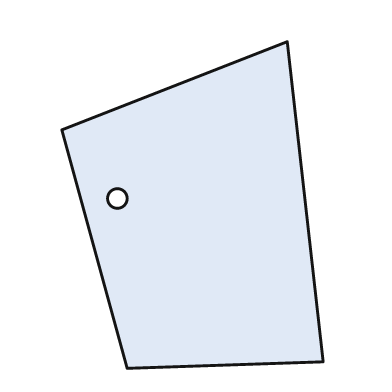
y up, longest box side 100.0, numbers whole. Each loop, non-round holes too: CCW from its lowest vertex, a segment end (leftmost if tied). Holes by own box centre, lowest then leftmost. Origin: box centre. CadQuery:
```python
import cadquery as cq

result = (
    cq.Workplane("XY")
    .moveTo(-20.0, -50.0)
    .lineTo(40.0, -48.0)
    .lineTo(29.0, 50.0)
    .lineTo(-40.0, 23.0)
    .close()
    .moveTo(-23.0, 2.0)
    .circle(3.0)
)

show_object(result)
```